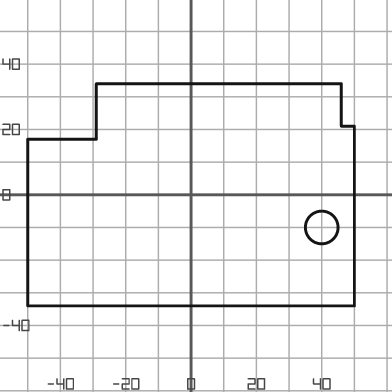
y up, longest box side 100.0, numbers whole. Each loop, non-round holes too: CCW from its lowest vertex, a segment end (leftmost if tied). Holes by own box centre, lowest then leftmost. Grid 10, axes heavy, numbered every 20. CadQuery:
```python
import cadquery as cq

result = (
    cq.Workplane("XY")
    .moveTo(-50.0, -34.0)
    .lineTo(50.0, -34.0)
    .lineTo(50.0, 21.0)
    .lineTo(46.0, 21.0)
    .lineTo(46.0, 34.0)
    .lineTo(-29.0, 34.0)
    .lineTo(-29.0, 17.0)
    .lineTo(-50.0, 17.0)
    .close()
    .moveTo(40.0, -10.0)
    .circle(5.0)
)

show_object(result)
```